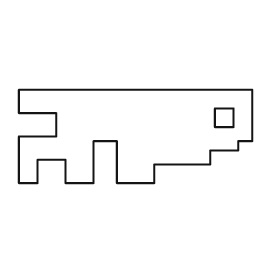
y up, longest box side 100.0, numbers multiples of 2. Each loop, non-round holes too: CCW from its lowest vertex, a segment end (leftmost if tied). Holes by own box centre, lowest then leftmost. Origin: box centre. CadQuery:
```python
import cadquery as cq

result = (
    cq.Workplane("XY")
    .moveTo(-50.0, -20.0)
    .lineTo(-42.0, -20.0)
    .lineTo(-42.0, -10.0)
    .lineTo(-30.0, -10.0)
    .lineTo(-30.0, -20.0)
    .lineTo(-18.0, -20.0)
    .lineTo(-18.0, -2.0)
    .lineTo(-8.0, -2.0)
    .lineTo(-8.0, -20.0)
    .lineTo(8.0, -20.0)
    .lineTo(8.0, -12.0)
    .lineTo(32.0, -12.0)
    .lineTo(32.0, -6.0)
    .lineTo(44.0, -6.0)
    .lineTo(44.0, -2.0)
    .lineTo(50.0, -2.0)
    .lineTo(50.0, 20.0)
    .lineTo(-50.0, 20.0)
    .lineTo(-50.0, 10.0)
    .lineTo(-34.0, 10.0)
    .lineTo(-34.0, 0.0)
    .lineTo(-50.0, 0.0)
    .close()
    .moveTo(34.0, 4.0)
    .lineTo(42.0, 4.0)
    .lineTo(42.0, 12.0)
    .lineTo(34.0, 12.0)
    .close()
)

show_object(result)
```